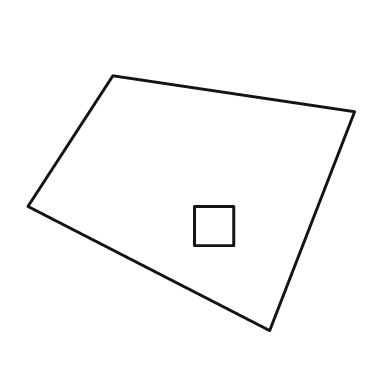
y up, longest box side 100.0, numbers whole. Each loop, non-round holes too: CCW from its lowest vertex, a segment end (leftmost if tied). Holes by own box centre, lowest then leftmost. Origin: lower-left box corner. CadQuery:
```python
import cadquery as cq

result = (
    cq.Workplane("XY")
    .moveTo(74.0, 0.0)
    .lineTo(100.0, 67.0)
    .lineTo(26.0, 78.0)
    .lineTo(0.0, 38.0)
    .close()
    .moveTo(51.0, 26.0)
    .lineTo(63.0, 26.0)
    .lineTo(63.0, 38.0)
    .lineTo(51.0, 38.0)
    .close()
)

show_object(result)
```